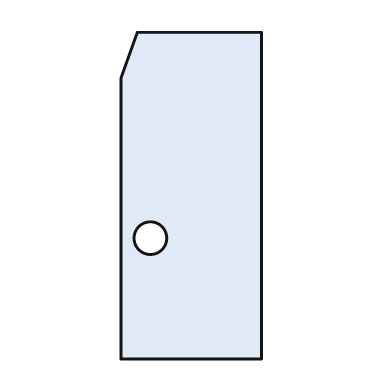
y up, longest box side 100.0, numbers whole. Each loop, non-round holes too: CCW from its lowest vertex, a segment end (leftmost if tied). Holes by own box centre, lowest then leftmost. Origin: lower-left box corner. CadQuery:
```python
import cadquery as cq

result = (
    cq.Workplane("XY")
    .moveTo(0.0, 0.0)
    .lineTo(43.0, 0.0)
    .lineTo(43.0, 100.0)
    .lineTo(5.0, 100.0)
    .lineTo(0.0, 86.0)
    .close()
    .moveTo(9.0, 37.0)
    .circle(5.0)
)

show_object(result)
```